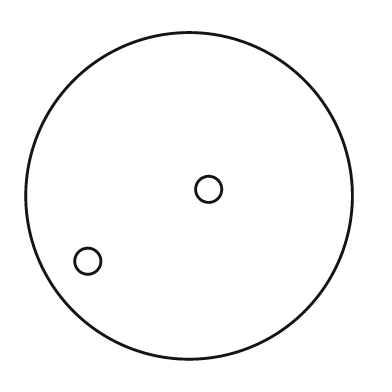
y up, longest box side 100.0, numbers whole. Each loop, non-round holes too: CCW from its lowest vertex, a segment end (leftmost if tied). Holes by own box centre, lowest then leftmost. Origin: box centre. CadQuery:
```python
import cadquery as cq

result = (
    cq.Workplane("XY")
    .moveTo(0.0, 0.0)
    .circle(50.0)
    .moveTo(-31.0, -20.0)
    .circle(4.0)
    .moveTo(6.0, 2.0)
    .circle(4.0)
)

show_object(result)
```